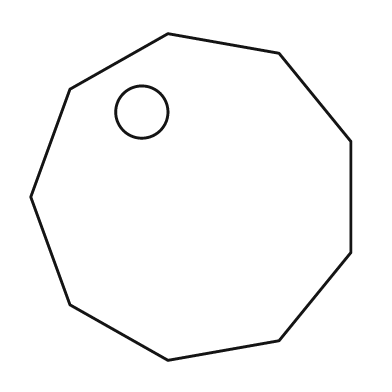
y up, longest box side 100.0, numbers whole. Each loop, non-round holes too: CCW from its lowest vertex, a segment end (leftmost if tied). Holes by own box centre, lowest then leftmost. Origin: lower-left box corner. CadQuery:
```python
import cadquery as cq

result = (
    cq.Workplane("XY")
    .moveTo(42.0, 0.0)
    .lineTo(76.0, 6.0)
    .lineTo(98.0, 33.0)
    .lineTo(98.0, 67.0)
    .lineTo(76.0, 94.0)
    .lineTo(42.0, 100.0)
    .lineTo(12.0, 83.0)
    .lineTo(0.0, 50.0)
    .lineTo(12.0, 17.0)
    .close()
    .moveTo(34.0, 76.0)
    .circle(8.0)
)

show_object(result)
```